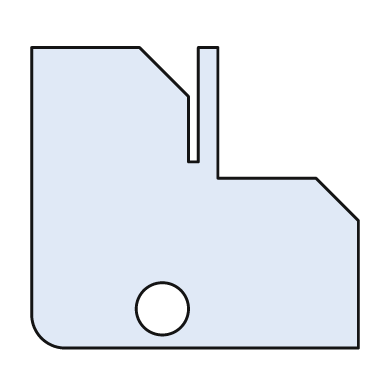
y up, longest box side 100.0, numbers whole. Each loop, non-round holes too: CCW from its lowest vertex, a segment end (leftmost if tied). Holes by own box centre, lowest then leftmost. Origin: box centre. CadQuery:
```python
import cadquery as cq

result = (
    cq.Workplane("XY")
    .moveTo(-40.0, -46.0)
    .lineTo(50.0, -46.0)
    .lineTo(50.0, -7.0)
    .lineTo(37.0, 6.0)
    .lineTo(7.0, 6.0)
    .lineTo(7.0, 46.0)
    .lineTo(1.0, 46.0)
    .lineTo(1.0, 11.0)
    .lineTo(-2.0, 11.0)
    .lineTo(-2.0, 31.0)
    .lineTo(-17.0, 46.0)
    .lineTo(-50.0, 46.0)
    .lineTo(-50.0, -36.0)
    .threePointArc((-47.0, -43.0), (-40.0, -46.0))
    .close()
    .moveTo(-10.0, -34.0)
    .circle(8.0)
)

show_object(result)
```